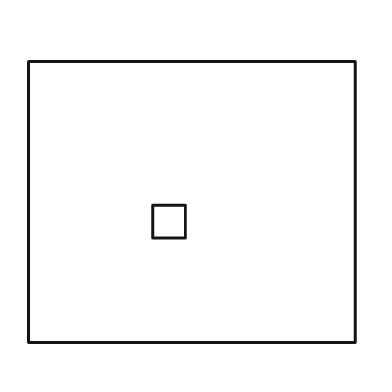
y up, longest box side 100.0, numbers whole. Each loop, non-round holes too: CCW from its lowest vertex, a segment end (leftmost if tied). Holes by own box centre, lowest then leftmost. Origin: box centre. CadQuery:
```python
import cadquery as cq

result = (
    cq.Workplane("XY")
    .moveTo(-50.0, -43.0)
    .lineTo(50.0, -43.0)
    .lineTo(50.0, 43.0)
    .lineTo(-50.0, 43.0)
    .close()
    .moveTo(-12.0, -11.0)
    .lineTo(-2.0, -11.0)
    .lineTo(-2.0, -1.0)
    .lineTo(-12.0, -1.0)
    .close()
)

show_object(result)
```